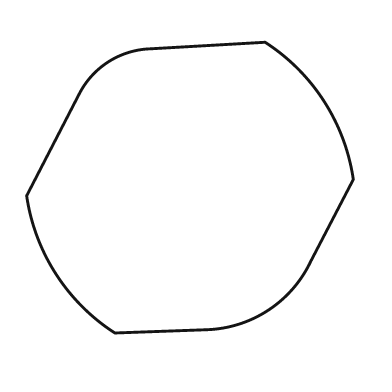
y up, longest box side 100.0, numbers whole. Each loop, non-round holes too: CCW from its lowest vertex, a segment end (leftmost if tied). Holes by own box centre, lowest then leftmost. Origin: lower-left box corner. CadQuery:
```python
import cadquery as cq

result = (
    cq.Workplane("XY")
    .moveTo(27.0, 0.0)
    .lineTo(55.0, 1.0)
    .threePointArc((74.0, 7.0), (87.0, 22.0))
    .lineTo(100.0, 47.0)
    .threePointArc((91.0, 71.0), (73.0, 89.0))
    .lineTo(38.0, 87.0)
    .threePointArc((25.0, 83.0), (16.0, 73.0))
    .lineTo(0.0, 42.0)
    .threePointArc((9.0, 18.0), (27.0, 0.0))
    .close()
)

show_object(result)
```